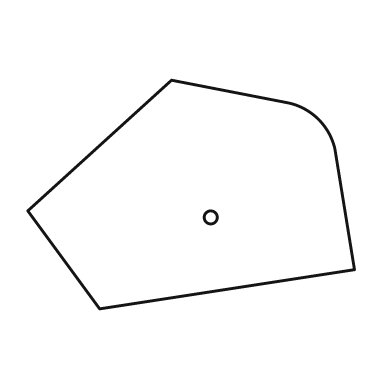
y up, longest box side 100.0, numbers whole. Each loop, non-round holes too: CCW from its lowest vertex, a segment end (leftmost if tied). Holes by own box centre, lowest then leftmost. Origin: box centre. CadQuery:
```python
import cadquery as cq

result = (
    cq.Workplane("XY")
    .moveTo(-28.0, -35.0)
    .lineTo(50.0, -23.0)
    .lineTo(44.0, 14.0)
    .threePointArc((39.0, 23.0), (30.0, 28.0))
    .lineTo(-6.0, 35.0)
    .lineTo(-50.0, -5.0)
    .close()
    .moveTo(6.0, -7.0)
    .circle(2.0)
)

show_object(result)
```